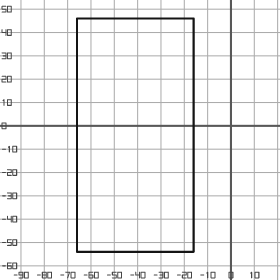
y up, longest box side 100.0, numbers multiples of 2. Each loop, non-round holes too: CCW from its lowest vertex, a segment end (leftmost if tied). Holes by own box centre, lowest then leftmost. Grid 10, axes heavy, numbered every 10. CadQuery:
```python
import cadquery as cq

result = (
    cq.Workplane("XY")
    .moveTo(-66.0, -54.0)
    .lineTo(-16.0, -54.0)
    .lineTo(-16.0, 46.0)
    .lineTo(-66.0, 46.0)
    .close()
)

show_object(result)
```